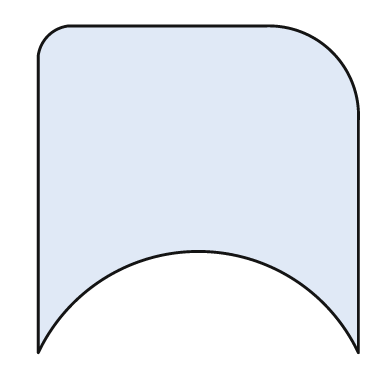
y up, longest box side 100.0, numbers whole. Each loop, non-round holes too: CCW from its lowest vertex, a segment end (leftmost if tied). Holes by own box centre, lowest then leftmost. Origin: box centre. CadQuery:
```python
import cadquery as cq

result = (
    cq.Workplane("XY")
    .moveTo(-49.0, -50.0)
    .threePointArc((0.0, -19.0), (49.0, -50.0))
    .lineTo(49.0, 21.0)
    .threePointArc((41.0, 42.0), (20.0, 50.0))
    .lineTo(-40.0, 50.0)
    .threePointArc((-46.0, 47.0), (-49.0, 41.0))
    .close()
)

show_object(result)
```